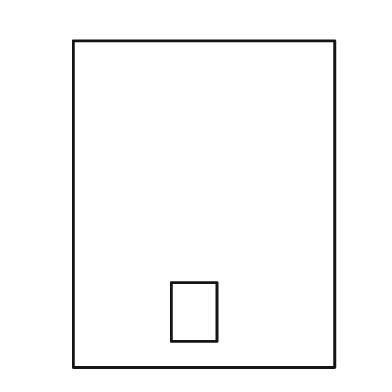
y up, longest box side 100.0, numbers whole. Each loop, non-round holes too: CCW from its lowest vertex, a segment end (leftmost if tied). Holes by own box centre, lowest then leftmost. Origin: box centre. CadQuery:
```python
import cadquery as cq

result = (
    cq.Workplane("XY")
    .moveTo(-40.0, -50.0)
    .lineTo(40.0, -50.0)
    .lineTo(40.0, 50.0)
    .lineTo(-40.0, 50.0)
    .close()
    .moveTo(-10.0, -42.0)
    .lineTo(4.0, -42.0)
    .lineTo(4.0, -24.0)
    .lineTo(-10.0, -24.0)
    .close()
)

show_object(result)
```